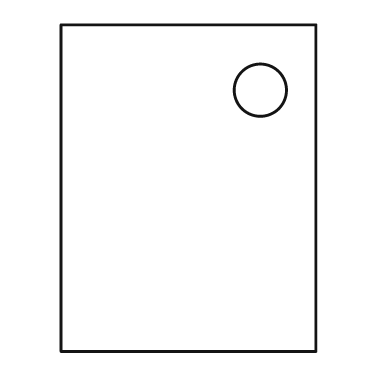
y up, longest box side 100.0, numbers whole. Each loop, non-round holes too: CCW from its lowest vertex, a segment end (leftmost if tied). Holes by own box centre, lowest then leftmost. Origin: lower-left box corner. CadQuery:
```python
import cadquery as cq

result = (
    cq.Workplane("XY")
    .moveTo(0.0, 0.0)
    .lineTo(78.0, 0.0)
    .lineTo(78.0, 100.0)
    .lineTo(0.0, 100.0)
    .close()
    .moveTo(61.0, 80.0)
    .circle(8.0)
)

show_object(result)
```